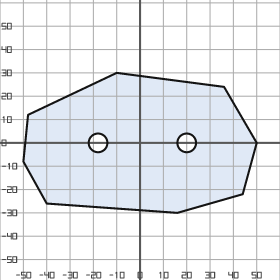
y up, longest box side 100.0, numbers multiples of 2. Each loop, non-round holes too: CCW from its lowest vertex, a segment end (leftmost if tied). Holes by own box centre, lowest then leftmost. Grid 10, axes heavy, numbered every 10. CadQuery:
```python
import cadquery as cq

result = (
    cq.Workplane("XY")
    .moveTo(16.0, -30.0)
    .lineTo(44.0, -22.0)
    .lineTo(50.0, 0.0)
    .lineTo(36.0, 24.0)
    .lineTo(-10.0, 30.0)
    .lineTo(-48.0, 12.0)
    .lineTo(-50.0, -8.0)
    .lineTo(-40.0, -26.0)
    .close()
    .moveTo(-18.0, 0.0)
    .circle(4.0)
    .moveTo(20.0, 0.0)
    .circle(4.0)
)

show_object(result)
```